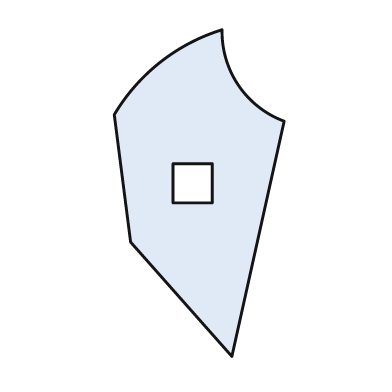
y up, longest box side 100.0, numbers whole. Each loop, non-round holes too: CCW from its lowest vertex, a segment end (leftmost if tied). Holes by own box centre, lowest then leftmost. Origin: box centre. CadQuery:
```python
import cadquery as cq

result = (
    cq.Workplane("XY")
    .moveTo(10.0, -50.0)
    .lineTo(26.0, 22.0)
    .threePointArc((12.0, 33.0), (7.0, 50.0))
    .threePointArc((-12.0, 40.0), (-26.0, 24.0))
    .lineTo(-21.0, -15.0)
    .close()
    .moveTo(-8.0, -3.0)
    .lineTo(4.0, -3.0)
    .lineTo(4.0, 9.0)
    .lineTo(-8.0, 9.0)
    .close()
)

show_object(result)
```